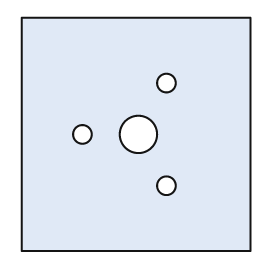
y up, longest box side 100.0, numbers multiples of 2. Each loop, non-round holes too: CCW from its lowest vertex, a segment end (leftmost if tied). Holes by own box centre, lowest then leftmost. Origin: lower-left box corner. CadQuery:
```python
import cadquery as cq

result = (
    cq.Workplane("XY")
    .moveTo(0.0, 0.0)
    .lineTo(98.0, 0.0)
    .lineTo(98.0, 100.0)
    .lineTo(0.0, 100.0)
    .close()
    .moveTo(62.0, 28.0)
    .circle(4.0)
    .moveTo(26.0, 50.0)
    .circle(4.0)
    .moveTo(50.0, 50.0)
    .circle(8.0)
    .moveTo(62.0, 72.0)
    .circle(4.0)
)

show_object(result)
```